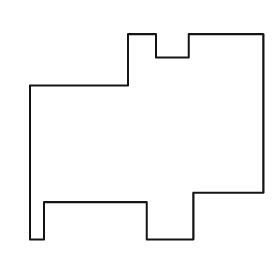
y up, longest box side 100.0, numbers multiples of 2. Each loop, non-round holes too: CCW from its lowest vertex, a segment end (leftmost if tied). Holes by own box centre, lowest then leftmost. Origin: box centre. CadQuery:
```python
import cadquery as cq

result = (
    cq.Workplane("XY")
    .moveTo(-50.0, -44.0)
    .lineTo(-44.0, -44.0)
    .lineTo(-44.0, -28.0)
    .lineTo(0.0, -28.0)
    .lineTo(0.0, -44.0)
    .lineTo(20.0, -44.0)
    .lineTo(20.0, -24.0)
    .lineTo(50.0, -24.0)
    .lineTo(50.0, 44.0)
    .lineTo(18.0, 44.0)
    .lineTo(18.0, 34.0)
    .lineTo(4.0, 34.0)
    .lineTo(4.0, 44.0)
    .lineTo(-8.0, 44.0)
    .lineTo(-8.0, 22.0)
    .lineTo(-50.0, 22.0)
    .close()
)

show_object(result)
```